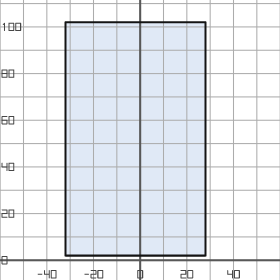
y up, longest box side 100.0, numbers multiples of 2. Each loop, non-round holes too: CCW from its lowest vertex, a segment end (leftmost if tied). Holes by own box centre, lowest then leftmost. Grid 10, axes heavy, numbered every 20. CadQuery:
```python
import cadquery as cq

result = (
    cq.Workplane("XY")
    .moveTo(-32.0, 2.0)
    .lineTo(28.0, 2.0)
    .lineTo(28.0, 102.0)
    .lineTo(-32.0, 102.0)
    .close()
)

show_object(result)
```